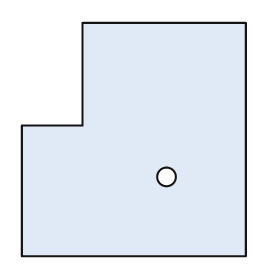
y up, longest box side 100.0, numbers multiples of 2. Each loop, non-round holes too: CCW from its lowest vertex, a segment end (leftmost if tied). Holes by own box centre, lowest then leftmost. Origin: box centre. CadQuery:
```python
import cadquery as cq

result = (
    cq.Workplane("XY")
    .moveTo(-48.0, -50.0)
    .lineTo(48.0, -50.0)
    .lineTo(48.0, 50.0)
    .lineTo(-22.0, 50.0)
    .lineTo(-22.0, 6.0)
    .lineTo(-48.0, 6.0)
    .close()
    .moveTo(14.0, -16.0)
    .circle(4.0)
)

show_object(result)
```